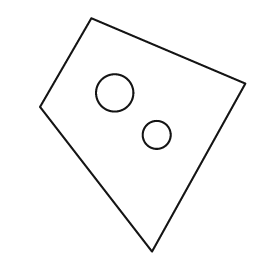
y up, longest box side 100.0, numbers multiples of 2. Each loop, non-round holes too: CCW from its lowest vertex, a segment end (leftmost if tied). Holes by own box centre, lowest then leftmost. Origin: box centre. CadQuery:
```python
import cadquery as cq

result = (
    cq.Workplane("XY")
    .moveTo(4.0, -50.0)
    .lineTo(44.0, 22.0)
    .lineTo(-22.0, 50.0)
    .lineTo(-44.0, 12.0)
    .close()
    .moveTo(6.0, 0.0)
    .circle(6.0)
    .moveTo(-12.0, 18.0)
    .circle(8.0)
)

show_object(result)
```